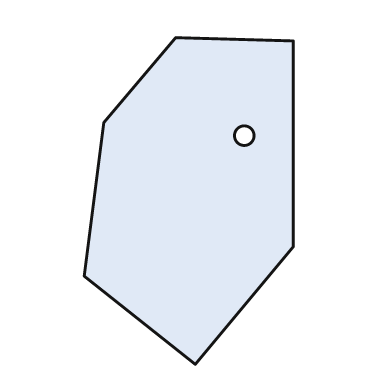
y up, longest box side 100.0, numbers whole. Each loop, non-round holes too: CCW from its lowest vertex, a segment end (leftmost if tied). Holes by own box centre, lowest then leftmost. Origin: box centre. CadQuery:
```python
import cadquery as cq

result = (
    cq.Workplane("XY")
    .moveTo(2.0, -50.0)
    .lineTo(32.0, -14.0)
    .lineTo(32.0, 49.0)
    .lineTo(-4.0, 50.0)
    .lineTo(-26.0, 24.0)
    .lineTo(-32.0, -23.0)
    .close()
    .moveTo(17.0, 20.0)
    .circle(3.0)
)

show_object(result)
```